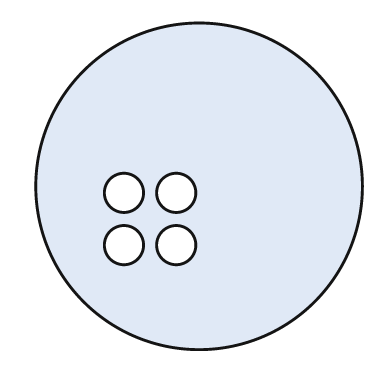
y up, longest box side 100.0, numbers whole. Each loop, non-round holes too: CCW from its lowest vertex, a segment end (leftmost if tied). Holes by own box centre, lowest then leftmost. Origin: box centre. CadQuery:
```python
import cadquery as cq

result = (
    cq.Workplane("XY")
    .moveTo(0.0, 0.0)
    .circle(50.0)
    .moveTo(-23.0, -18.0)
    .circle(6.0)
    .moveTo(-7.0, -18.0)
    .circle(6.0)
    .moveTo(-23.0, -2.0)
    .circle(6.0)
    .moveTo(-7.0, -2.0)
    .circle(6.0)
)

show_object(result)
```